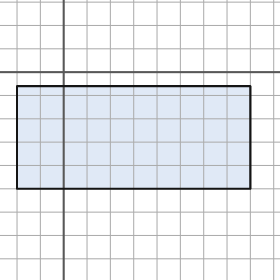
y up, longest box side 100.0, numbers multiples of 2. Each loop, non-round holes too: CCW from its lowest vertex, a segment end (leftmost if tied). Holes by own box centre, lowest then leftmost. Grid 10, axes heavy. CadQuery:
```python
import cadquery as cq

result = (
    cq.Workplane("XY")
    .moveTo(-20.0, -50.0)
    .lineTo(80.0, -50.0)
    .lineTo(80.0, -6.0)
    .lineTo(-20.0, -6.0)
    .close()
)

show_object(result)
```